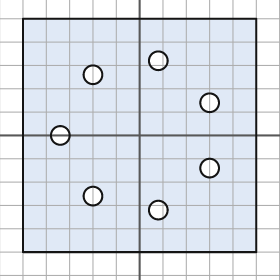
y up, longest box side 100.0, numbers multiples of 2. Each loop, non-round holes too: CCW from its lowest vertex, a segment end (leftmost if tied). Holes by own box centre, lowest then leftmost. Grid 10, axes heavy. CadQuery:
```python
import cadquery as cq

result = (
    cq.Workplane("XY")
    .moveTo(-50.0, -50.0)
    .lineTo(50.0, -50.0)
    .lineTo(50.0, 50.0)
    .lineTo(-50.0, 50.0)
    .close()
    .moveTo(8.0, -32.0)
    .circle(4.0)
    .moveTo(-20.0, -26.0)
    .circle(4.0)
    .moveTo(30.0, -14.0)
    .circle(4.0)
    .moveTo(-34.0, 0.0)
    .circle(4.0)
    .moveTo(30.0, 14.0)
    .circle(4.0)
    .moveTo(-20.0, 26.0)
    .circle(4.0)
    .moveTo(8.0, 32.0)
    .circle(4.0)
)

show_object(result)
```